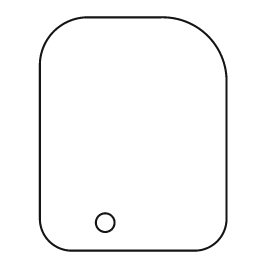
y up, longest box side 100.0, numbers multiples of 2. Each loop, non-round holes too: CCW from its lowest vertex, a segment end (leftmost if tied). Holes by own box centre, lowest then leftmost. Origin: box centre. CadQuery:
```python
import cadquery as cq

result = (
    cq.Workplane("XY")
    .moveTo(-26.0, -50.0)
    .lineTo(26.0, -50.0)
    .threePointArc((36.0, -46.0), (40.0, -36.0))
    .lineTo(40.0, 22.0)
    .threePointArc((32.0, 42.0), (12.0, 50.0))
    .lineTo(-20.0, 50.0)
    .threePointArc((-34.0, 44.0), (-40.0, 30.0))
    .lineTo(-40.0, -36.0)
    .threePointArc((-36.0, -46.0), (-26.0, -50.0))
    .close()
    .moveTo(-12.0, -38.0)
    .circle(4.0)
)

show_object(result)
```